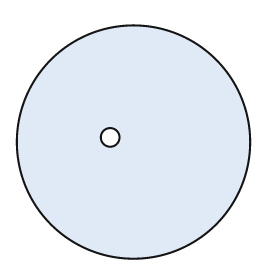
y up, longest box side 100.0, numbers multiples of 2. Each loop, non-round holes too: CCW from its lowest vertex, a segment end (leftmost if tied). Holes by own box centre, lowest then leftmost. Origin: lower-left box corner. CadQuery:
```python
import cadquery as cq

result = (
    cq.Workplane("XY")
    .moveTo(50.0, 50.0)
    .circle(50.0)
    .moveTo(40.0, 52.0)
    .circle(4.0)
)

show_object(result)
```